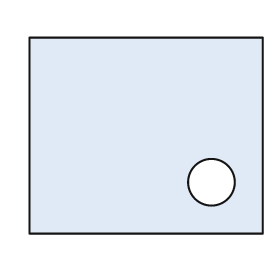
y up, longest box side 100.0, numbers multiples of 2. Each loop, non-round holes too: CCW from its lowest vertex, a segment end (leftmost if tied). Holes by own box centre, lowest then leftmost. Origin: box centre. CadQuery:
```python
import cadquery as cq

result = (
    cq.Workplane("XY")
    .moveTo(-50.0, -42.0)
    .lineTo(50.0, -42.0)
    .lineTo(50.0, 42.0)
    .lineTo(-50.0, 42.0)
    .close()
    .moveTo(28.0, -20.0)
    .circle(10.0)
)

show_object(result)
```